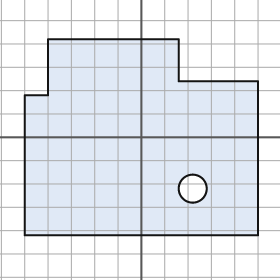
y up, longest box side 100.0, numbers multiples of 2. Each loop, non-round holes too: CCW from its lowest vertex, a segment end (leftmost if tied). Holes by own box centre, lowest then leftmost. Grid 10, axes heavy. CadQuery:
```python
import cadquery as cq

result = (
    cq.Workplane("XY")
    .moveTo(-50.0, -42.0)
    .lineTo(50.0, -42.0)
    .lineTo(50.0, 24.0)
    .lineTo(16.0, 24.0)
    .lineTo(16.0, 42.0)
    .lineTo(-40.0, 42.0)
    .lineTo(-40.0, 18.0)
    .lineTo(-50.0, 18.0)
    .close()
    .moveTo(22.0, -22.0)
    .circle(6.0)
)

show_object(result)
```